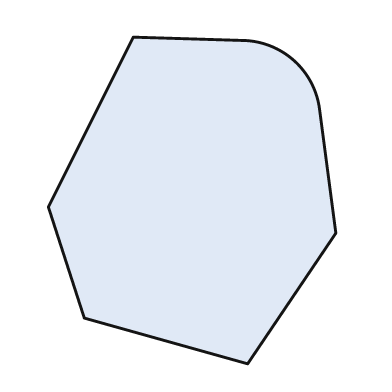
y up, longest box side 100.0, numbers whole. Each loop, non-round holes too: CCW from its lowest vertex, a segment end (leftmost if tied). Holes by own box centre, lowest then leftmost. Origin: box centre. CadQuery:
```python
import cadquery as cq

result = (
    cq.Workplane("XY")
    .moveTo(17.0, -50.0)
    .lineTo(44.0, -10.0)
    .lineTo(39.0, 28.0)
    .threePointArc((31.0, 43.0), (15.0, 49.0))
    .lineTo(-18.0, 50.0)
    .lineTo(-44.0, -2.0)
    .lineTo(-33.0, -36.0)
    .close()
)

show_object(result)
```